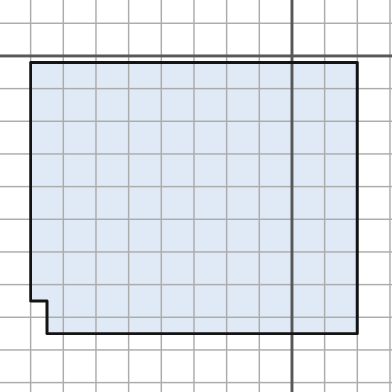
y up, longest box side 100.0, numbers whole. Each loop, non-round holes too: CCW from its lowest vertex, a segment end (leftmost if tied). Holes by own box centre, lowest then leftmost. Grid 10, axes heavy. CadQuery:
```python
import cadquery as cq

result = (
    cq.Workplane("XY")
    .moveTo(-75.0, -85.0)
    .lineTo(20.0, -85.0)
    .lineTo(20.0, -2.0)
    .lineTo(-80.0, -2.0)
    .lineTo(-80.0, -75.0)
    .lineTo(-75.0, -75.0)
    .close()
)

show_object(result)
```